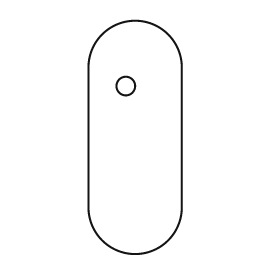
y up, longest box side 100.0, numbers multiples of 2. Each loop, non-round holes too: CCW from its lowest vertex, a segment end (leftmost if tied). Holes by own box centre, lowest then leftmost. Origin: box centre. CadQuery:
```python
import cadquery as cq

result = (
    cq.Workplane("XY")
    .moveTo(-20.0, -30.0)
    .threePointArc((0.0, -50.0), (20.0, -30.0))
    .lineTo(20.0, 30.0)
    .threePointArc((0.0, 50.0), (-20.0, 30.0))
    .close()
    .moveTo(-4.0, 22.0)
    .circle(4.0)
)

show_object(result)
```